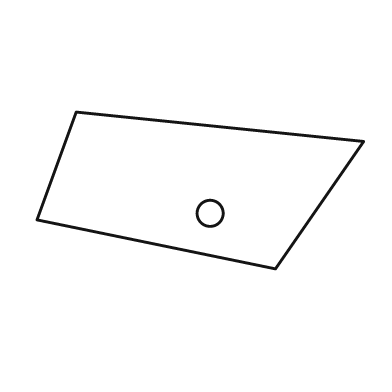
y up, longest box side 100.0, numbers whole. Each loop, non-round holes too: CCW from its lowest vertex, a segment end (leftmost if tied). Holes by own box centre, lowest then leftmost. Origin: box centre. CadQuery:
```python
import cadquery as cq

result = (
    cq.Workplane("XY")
    .moveTo(23.0, -24.0)
    .lineTo(50.0, 15.0)
    .lineTo(-38.0, 24.0)
    .lineTo(-50.0, -9.0)
    .close()
    .moveTo(3.0, -7.0)
    .circle(4.0)
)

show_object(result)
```